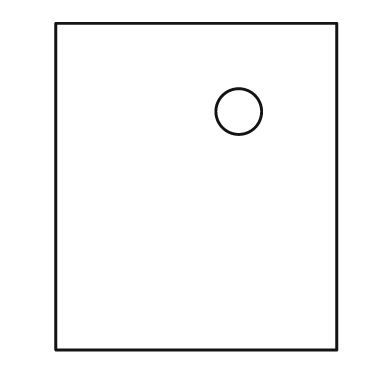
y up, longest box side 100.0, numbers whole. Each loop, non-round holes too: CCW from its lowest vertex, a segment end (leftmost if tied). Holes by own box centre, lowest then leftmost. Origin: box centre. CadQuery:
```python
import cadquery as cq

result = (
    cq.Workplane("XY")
    .moveTo(-43.0, -50.0)
    .lineTo(43.0, -50.0)
    .lineTo(43.0, 50.0)
    .lineTo(-43.0, 50.0)
    .close()
    .moveTo(13.0, 23.0)
    .circle(7.0)
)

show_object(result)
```